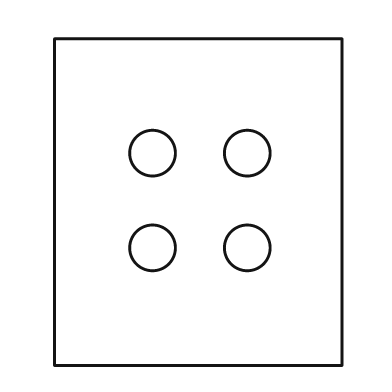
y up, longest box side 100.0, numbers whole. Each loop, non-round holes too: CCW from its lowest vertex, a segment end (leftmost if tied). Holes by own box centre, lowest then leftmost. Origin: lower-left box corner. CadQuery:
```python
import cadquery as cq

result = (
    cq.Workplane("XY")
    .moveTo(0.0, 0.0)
    .lineTo(88.0, 0.0)
    .lineTo(88.0, 100.0)
    .lineTo(0.0, 100.0)
    .close()
    .moveTo(30.0, 36.0)
    .circle(7.0)
    .moveTo(59.0, 36.0)
    .circle(7.0)
    .moveTo(30.0, 65.0)
    .circle(7.0)
    .moveTo(59.0, 65.0)
    .circle(7.0)
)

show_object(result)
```